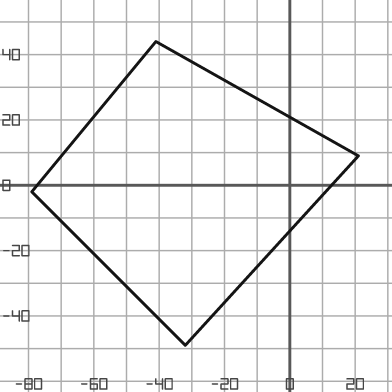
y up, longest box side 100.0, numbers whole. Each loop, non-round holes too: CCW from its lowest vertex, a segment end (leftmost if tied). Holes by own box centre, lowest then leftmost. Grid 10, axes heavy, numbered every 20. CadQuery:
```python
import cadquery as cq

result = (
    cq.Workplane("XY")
    .moveTo(-32.0, -49.0)
    .lineTo(21.0, 9.0)
    .lineTo(-41.0, 44.0)
    .lineTo(-79.0, -2.0)
    .close()
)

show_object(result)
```